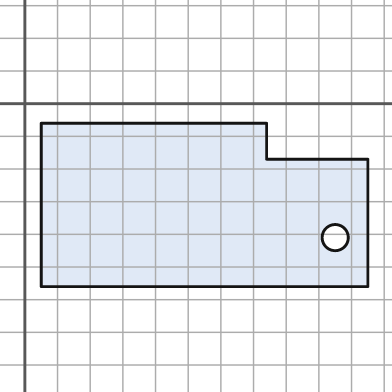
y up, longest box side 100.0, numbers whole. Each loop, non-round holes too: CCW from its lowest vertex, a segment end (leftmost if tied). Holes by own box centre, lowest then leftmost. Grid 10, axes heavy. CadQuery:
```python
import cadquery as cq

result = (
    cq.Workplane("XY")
    .moveTo(5.0, -56.0)
    .lineTo(105.0, -56.0)
    .lineTo(105.0, -17.0)
    .lineTo(74.0, -17.0)
    .lineTo(74.0, -6.0)
    .lineTo(5.0, -6.0)
    .close()
    .moveTo(95.0, -41.0)
    .circle(4.0)
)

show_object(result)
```